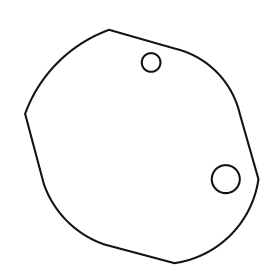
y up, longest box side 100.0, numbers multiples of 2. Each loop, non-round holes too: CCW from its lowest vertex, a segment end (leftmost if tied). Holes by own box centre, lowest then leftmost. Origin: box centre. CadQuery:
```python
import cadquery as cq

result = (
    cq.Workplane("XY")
    .moveTo(14.0, -50.0)
    .threePointArc((38.0, -38.0), (50.0, -14.0))
    .lineTo(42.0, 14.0)
    .threePointArc((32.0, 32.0), (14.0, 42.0))
    .lineTo(-14.0, 50.0)
    .threePointArc((-36.0, 36.0), (-50.0, 14.0))
    .lineTo(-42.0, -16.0)
    .threePointArc((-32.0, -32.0), (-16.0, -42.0))
    .close()
    .moveTo(36.0, -14.0)
    .circle(6.0)
    .moveTo(4.0, 36.0)
    .circle(4.0)
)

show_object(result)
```